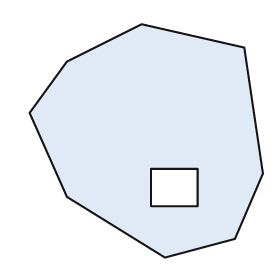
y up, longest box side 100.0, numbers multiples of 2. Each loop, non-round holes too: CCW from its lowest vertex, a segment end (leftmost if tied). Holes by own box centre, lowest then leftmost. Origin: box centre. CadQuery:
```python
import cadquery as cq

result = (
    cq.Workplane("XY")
    .moveTo(8.0, -50.0)
    .lineTo(38.0, -42.0)
    .lineTo(50.0, -14.0)
    .lineTo(42.0, 40.0)
    .lineTo(-2.0, 50.0)
    .lineTo(-34.0, 34.0)
    .lineTo(-50.0, 12.0)
    .lineTo(-34.0, -24.0)
    .close()
    .moveTo(2.0, -28.0)
    .lineTo(22.0, -28.0)
    .lineTo(22.0, -12.0)
    .lineTo(2.0, -12.0)
    .close()
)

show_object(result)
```